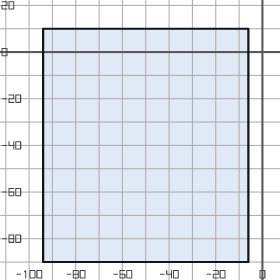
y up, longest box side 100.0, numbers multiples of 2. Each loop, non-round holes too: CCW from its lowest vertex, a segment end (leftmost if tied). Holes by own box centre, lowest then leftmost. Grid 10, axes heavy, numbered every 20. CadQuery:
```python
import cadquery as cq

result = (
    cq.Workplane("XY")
    .moveTo(-94.0, -90.0)
    .lineTo(-6.0, -90.0)
    .lineTo(-6.0, 10.0)
    .lineTo(-94.0, 10.0)
    .close()
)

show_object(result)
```